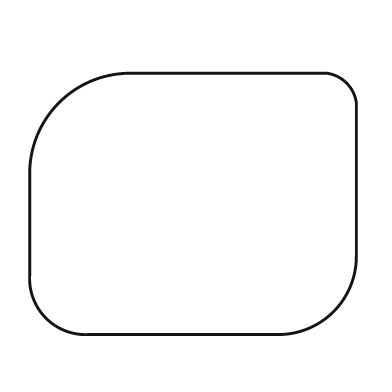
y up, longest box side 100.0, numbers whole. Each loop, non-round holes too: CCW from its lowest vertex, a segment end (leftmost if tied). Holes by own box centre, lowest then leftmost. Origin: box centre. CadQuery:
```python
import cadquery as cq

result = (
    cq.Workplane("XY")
    .moveTo(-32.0, -40.0)
    .lineTo(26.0, -40.0)
    .threePointArc((43.0, -33.0), (50.0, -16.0))
    .lineTo(50.0, 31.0)
    .threePointArc((47.0, 37.0), (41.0, 40.0))
    .lineTo(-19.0, 40.0)
    .threePointArc((-41.0, 31.0), (-50.0, 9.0))
    .lineTo(-50.0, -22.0)
    .threePointArc((-45.0, -35.0), (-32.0, -40.0))
    .close()
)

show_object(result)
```